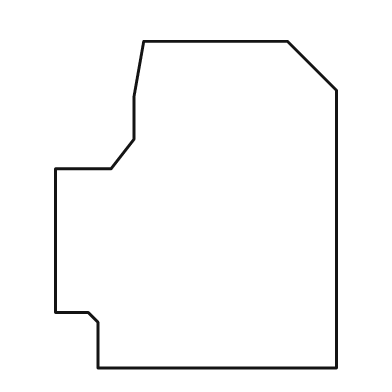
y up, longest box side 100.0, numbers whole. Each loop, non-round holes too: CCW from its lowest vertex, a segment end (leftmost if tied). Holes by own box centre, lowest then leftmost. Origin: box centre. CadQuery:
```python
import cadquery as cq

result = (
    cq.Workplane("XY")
    .moveTo(-30.0, -50.0)
    .lineTo(43.0, -50.0)
    .lineTo(43.0, 35.0)
    .lineTo(28.0, 50.0)
    .lineTo(-16.0, 50.0)
    .lineTo(-19.0, 33.0)
    .lineTo(-19.0, 20.0)
    .lineTo(-26.0, 11.0)
    .lineTo(-43.0, 11.0)
    .lineTo(-43.0, -33.0)
    .lineTo(-33.0, -33.0)
    .lineTo(-30.0, -36.0)
    .close()
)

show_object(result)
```